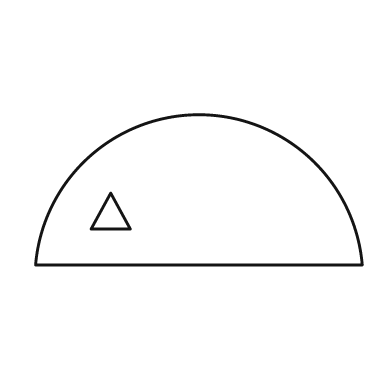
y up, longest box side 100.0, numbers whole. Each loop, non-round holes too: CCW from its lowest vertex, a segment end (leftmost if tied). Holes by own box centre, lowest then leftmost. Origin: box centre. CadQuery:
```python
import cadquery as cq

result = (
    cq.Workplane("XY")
    .moveTo(-50.0, -23.0)
    .lineTo(50.0, -23.0)
    .threePointArc((0.0, 23.0), (-50.0, -23.0))
    .close()
    .moveTo(-33.0, -12.0)
    .lineTo(-21.0, -12.0)
    .lineTo(-27.0, -1.0)
    .close()
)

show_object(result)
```